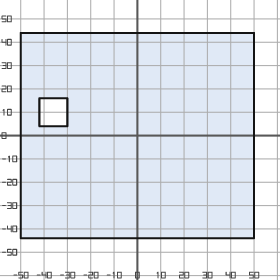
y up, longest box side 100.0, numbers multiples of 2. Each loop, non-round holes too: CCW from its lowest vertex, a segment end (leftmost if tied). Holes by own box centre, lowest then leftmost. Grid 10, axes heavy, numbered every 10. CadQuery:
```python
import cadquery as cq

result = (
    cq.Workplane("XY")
    .moveTo(-50.0, -44.0)
    .lineTo(50.0, -44.0)
    .lineTo(50.0, 44.0)
    .lineTo(-50.0, 44.0)
    .close()
    .moveTo(-42.0, 4.0)
    .lineTo(-30.0, 4.0)
    .lineTo(-30.0, 16.0)
    .lineTo(-42.0, 16.0)
    .close()
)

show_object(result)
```